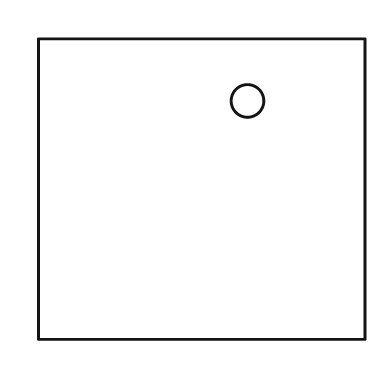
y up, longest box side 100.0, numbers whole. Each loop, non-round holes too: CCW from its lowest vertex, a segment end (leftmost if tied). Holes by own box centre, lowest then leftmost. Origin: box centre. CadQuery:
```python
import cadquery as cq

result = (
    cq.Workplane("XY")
    .moveTo(-50.0, -46.0)
    .lineTo(50.0, -46.0)
    .lineTo(50.0, 46.0)
    .lineTo(-50.0, 46.0)
    .close()
    .moveTo(14.0, 27.0)
    .circle(5.0)
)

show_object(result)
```